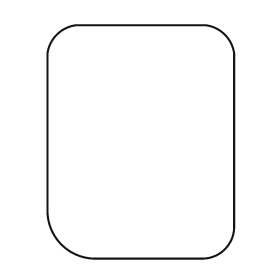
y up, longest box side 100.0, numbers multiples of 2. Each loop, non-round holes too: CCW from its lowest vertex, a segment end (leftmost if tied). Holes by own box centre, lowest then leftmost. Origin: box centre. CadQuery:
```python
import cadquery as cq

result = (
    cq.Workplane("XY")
    .moveTo(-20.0, -50.0)
    .lineTo(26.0, -50.0)
    .threePointArc((36.0, -46.0), (40.0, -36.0))
    .lineTo(40.0, 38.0)
    .threePointArc((36.0, 46.0), (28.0, 50.0))
    .lineTo(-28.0, 50.0)
    .threePointArc((-36.0, 46.0), (-40.0, 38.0))
    .lineTo(-40.0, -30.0)
    .threePointArc((-34.0, -44.0), (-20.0, -50.0))
    .close()
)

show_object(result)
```